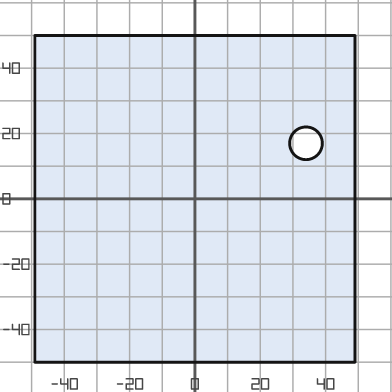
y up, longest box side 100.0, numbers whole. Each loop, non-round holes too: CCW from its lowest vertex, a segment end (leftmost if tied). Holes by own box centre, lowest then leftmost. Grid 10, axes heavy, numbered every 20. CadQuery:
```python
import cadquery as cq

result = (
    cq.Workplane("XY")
    .moveTo(-49.0, -50.0)
    .lineTo(49.0, -50.0)
    .lineTo(49.0, 50.0)
    .lineTo(-49.0, 50.0)
    .close()
    .moveTo(34.0, 17.0)
    .circle(5.0)
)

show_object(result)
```